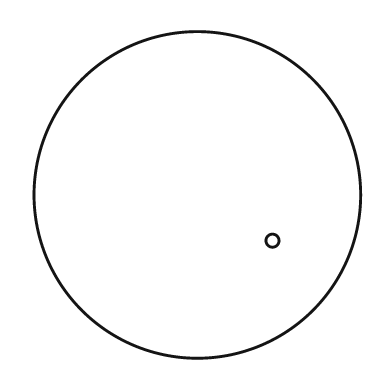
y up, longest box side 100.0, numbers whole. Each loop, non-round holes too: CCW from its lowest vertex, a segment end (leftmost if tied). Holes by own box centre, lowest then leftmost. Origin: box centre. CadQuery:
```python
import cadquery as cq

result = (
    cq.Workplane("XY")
    .moveTo(0.0, 0.0)
    .circle(50.0)
    .moveTo(23.0, -14.0)
    .circle(2.0)
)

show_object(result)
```